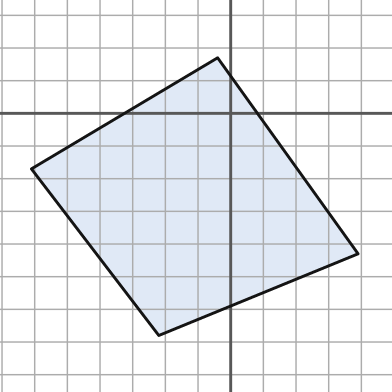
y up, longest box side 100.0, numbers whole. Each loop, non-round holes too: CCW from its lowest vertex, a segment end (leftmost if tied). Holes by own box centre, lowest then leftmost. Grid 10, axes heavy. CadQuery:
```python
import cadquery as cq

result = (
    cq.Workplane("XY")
    .moveTo(-22.0, -68.0)
    .lineTo(39.0, -43.0)
    .lineTo(-4.0, 17.0)
    .lineTo(-61.0, -17.0)
    .close()
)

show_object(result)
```